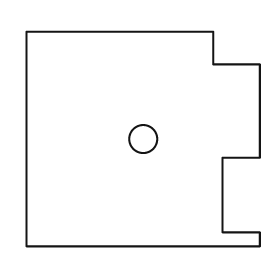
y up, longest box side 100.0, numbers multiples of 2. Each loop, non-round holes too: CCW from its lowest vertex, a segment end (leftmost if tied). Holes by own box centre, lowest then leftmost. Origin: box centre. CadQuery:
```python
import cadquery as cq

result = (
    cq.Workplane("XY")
    .moveTo(-50.0, -46.0)
    .lineTo(50.0, -46.0)
    .lineTo(50.0, -40.0)
    .lineTo(34.0, -40.0)
    .lineTo(34.0, -8.0)
    .lineTo(50.0, -8.0)
    .lineTo(50.0, 32.0)
    .lineTo(30.0, 32.0)
    .lineTo(30.0, 46.0)
    .lineTo(-50.0, 46.0)
    .close()
    .moveTo(0.0, 0.0)
    .circle(6.0)
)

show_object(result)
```